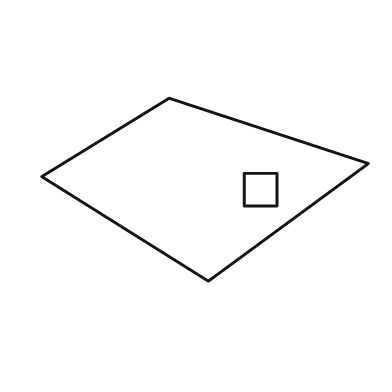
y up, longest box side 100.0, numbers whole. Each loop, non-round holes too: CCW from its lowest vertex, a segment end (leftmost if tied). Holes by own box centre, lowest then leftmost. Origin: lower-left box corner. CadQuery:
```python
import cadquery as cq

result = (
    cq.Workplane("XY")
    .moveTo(51.0, 0.0)
    .lineTo(100.0, 36.0)
    .lineTo(39.0, 56.0)
    .lineTo(0.0, 32.0)
    .close()
    .moveTo(62.0, 23.0)
    .lineTo(72.0, 23.0)
    .lineTo(72.0, 33.0)
    .lineTo(62.0, 33.0)
    .close()
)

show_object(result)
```